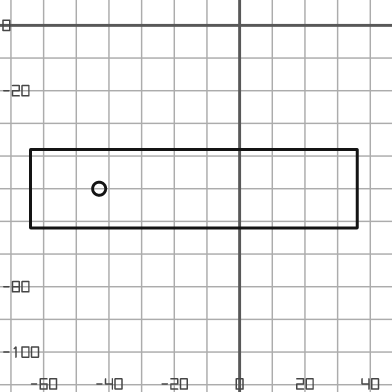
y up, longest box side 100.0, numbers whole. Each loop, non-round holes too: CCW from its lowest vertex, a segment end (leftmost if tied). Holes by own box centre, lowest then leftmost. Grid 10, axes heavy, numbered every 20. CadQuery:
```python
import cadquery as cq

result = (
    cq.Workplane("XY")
    .moveTo(-64.0, -62.0)
    .lineTo(36.0, -62.0)
    .lineTo(36.0, -38.0)
    .lineTo(-64.0, -38.0)
    .close()
    .moveTo(-43.0, -50.0)
    .circle(2.0)
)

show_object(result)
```